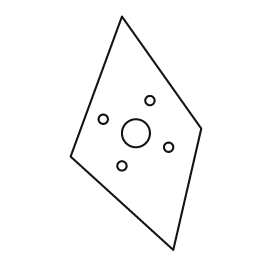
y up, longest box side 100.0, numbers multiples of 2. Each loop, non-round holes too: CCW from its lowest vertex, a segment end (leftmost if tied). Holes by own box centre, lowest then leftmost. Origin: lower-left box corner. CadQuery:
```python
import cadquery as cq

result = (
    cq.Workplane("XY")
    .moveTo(44.0, 0.0)
    .lineTo(56.0, 52.0)
    .lineTo(22.0, 100.0)
    .lineTo(0.0, 40.0)
    .close()
    .moveTo(22.0, 36.0)
    .circle(2.0)
    .moveTo(42.0, 44.0)
    .circle(2.0)
    .moveTo(28.0, 50.0)
    .circle(6.0)
    .moveTo(14.0, 56.0)
    .circle(2.0)
    .moveTo(34.0, 64.0)
    .circle(2.0)
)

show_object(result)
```